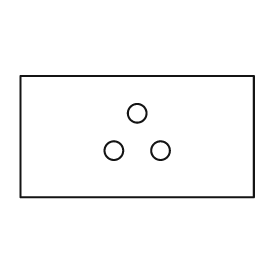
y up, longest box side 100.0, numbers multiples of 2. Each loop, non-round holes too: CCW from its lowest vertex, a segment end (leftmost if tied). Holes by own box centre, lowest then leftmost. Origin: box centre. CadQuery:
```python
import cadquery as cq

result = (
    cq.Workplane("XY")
    .moveTo(-50.0, -26.0)
    .lineTo(50.0, -26.0)
    .lineTo(50.0, 26.0)
    .lineTo(-50.0, 26.0)
    .close()
    .moveTo(-10.0, -6.0)
    .circle(4.0)
    .moveTo(10.0, -6.0)
    .circle(4.0)
    .moveTo(0.0, 10.0)
    .circle(4.0)
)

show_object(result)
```